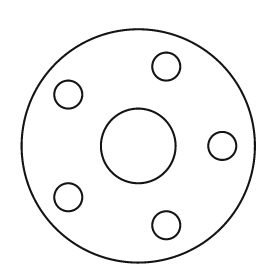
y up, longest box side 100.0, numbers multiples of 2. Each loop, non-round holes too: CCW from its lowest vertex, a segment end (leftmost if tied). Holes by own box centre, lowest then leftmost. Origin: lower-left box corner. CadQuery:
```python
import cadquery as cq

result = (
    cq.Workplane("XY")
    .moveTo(50.0, 50.0)
    .circle(50.0)
    .moveTo(62.0, 16.0)
    .circle(6.0)
    .moveTo(20.0, 28.0)
    .circle(6.0)
    .moveTo(50.0, 50.0)
    .circle(16.0)
    .moveTo(86.0, 50.0)
    .circle(6.0)
    .moveTo(20.0, 72.0)
    .circle(6.0)
    .moveTo(62.0, 84.0)
    .circle(6.0)
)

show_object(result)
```